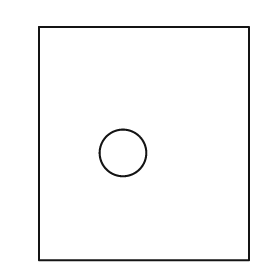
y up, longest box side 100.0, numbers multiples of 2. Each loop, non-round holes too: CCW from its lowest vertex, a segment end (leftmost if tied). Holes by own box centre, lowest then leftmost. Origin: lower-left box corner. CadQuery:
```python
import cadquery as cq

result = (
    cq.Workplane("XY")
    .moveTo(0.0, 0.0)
    .lineTo(90.0, 0.0)
    .lineTo(90.0, 100.0)
    .lineTo(0.0, 100.0)
    .close()
    .moveTo(36.0, 46.0)
    .circle(10.0)
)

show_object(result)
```